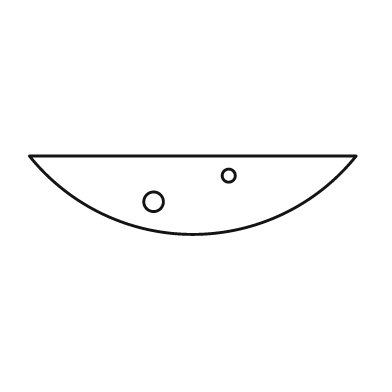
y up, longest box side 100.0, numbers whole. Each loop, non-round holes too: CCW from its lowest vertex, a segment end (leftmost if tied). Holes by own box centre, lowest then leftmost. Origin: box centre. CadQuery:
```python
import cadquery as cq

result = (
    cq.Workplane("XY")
    .moveTo(-50.0, 12.0)
    .threePointArc((0.0, -12.0), (50.0, 12.0))
    .close()
    .moveTo(-12.0, -2.0)
    .circle(3.0)
    .moveTo(11.0, 6.0)
    .circle(2.0)
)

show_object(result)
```